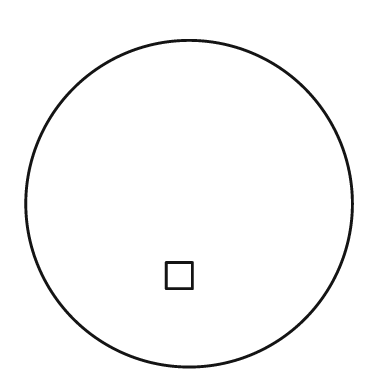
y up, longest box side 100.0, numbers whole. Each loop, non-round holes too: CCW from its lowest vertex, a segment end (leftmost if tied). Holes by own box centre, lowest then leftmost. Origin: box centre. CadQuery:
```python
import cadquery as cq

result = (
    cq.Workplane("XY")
    .moveTo(0.0, 0.0)
    .circle(50.0)
    .moveTo(-7.0, -26.0)
    .lineTo(1.0, -26.0)
    .lineTo(1.0, -18.0)
    .lineTo(-7.0, -18.0)
    .close()
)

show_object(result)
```